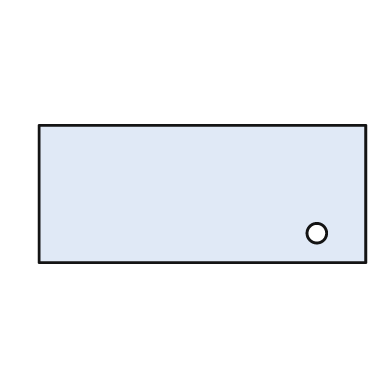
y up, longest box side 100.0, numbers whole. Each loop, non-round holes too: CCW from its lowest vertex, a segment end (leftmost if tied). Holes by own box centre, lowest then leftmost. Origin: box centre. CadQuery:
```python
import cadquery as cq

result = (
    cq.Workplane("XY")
    .moveTo(-50.0, -21.0)
    .lineTo(50.0, -21.0)
    .lineTo(50.0, 21.0)
    .lineTo(-50.0, 21.0)
    .close()
    .moveTo(35.0, -12.0)
    .circle(3.0)
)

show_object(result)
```